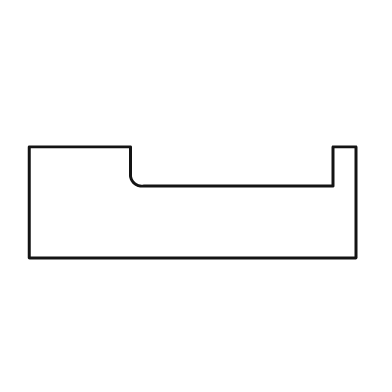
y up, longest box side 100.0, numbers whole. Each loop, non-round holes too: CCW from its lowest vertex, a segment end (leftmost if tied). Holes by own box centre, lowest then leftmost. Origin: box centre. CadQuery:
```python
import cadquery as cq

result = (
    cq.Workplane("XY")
    .moveTo(-50.0, -17.0)
    .lineTo(50.0, -17.0)
    .lineTo(50.0, 17.0)
    .lineTo(43.0, 17.0)
    .lineTo(43.0, 5.0)
    .lineTo(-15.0, 5.0)
    .threePointArc((-18.0, 6.0), (-19.0, 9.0))
    .lineTo(-19.0, 17.0)
    .lineTo(-50.0, 17.0)
    .close()
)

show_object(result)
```